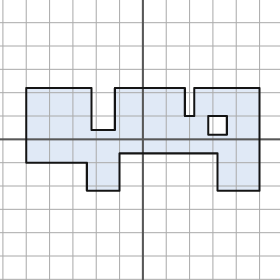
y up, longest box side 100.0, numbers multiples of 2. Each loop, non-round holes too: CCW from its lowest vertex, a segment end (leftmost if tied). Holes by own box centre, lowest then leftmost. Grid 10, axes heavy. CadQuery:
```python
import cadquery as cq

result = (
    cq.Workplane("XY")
    .moveTo(-24.0, -22.0)
    .lineTo(-10.0, -22.0)
    .lineTo(-10.0, -6.0)
    .lineTo(32.0, -6.0)
    .lineTo(32.0, -22.0)
    .lineTo(50.0, -22.0)
    .lineTo(50.0, 22.0)
    .lineTo(22.0, 22.0)
    .lineTo(22.0, 10.0)
    .lineTo(18.0, 10.0)
    .lineTo(18.0, 22.0)
    .lineTo(-12.0, 22.0)
    .lineTo(-12.0, 4.0)
    .lineTo(-22.0, 4.0)
    .lineTo(-22.0, 22.0)
    .lineTo(-50.0, 22.0)
    .lineTo(-50.0, -10.0)
    .lineTo(-24.0, -10.0)
    .close()
    .moveTo(28.0, 2.0)
    .lineTo(36.0, 2.0)
    .lineTo(36.0, 10.0)
    .lineTo(28.0, 10.0)
    .close()
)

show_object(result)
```